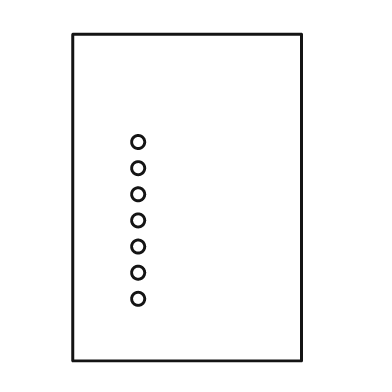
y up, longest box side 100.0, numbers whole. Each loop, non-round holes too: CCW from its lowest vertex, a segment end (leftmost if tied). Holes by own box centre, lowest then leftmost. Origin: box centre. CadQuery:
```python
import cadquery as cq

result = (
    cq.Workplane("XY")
    .moveTo(-35.0, -50.0)
    .lineTo(35.0, -50.0)
    .lineTo(35.0, 50.0)
    .lineTo(-35.0, 50.0)
    .close()
    .moveTo(-15.0, -31.0)
    .circle(2.0)
    .moveTo(-15.0, -23.0)
    .circle(2.0)
    .moveTo(-15.0, -15.0)
    .circle(2.0)
    .moveTo(-15.0, -7.0)
    .circle(2.0)
    .moveTo(-15.0, 1.0)
    .circle(2.0)
    .moveTo(-15.0, 9.0)
    .circle(2.0)
    .moveTo(-15.0, 17.0)
    .circle(2.0)
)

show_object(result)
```